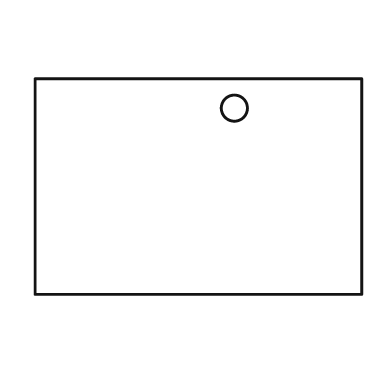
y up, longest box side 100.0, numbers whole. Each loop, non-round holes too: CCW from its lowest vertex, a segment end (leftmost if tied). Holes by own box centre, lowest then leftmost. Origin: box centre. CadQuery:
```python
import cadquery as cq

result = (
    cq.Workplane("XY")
    .moveTo(-50.0, -33.0)
    .lineTo(50.0, -33.0)
    .lineTo(50.0, 33.0)
    .lineTo(-50.0, 33.0)
    .close()
    .moveTo(11.0, 24.0)
    .circle(4.0)
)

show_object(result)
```